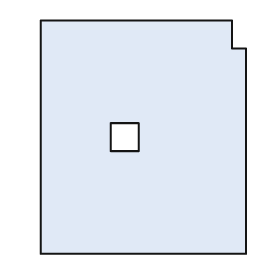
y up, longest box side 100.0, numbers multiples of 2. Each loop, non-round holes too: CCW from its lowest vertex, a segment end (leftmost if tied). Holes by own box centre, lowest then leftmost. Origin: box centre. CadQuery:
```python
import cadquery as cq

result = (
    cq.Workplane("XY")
    .moveTo(-44.0, -50.0)
    .lineTo(44.0, -50.0)
    .lineTo(44.0, 38.0)
    .lineTo(38.0, 38.0)
    .lineTo(38.0, 50.0)
    .lineTo(-44.0, 50.0)
    .close()
    .moveTo(-14.0, -6.0)
    .lineTo(-2.0, -6.0)
    .lineTo(-2.0, 6.0)
    .lineTo(-14.0, 6.0)
    .close()
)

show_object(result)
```